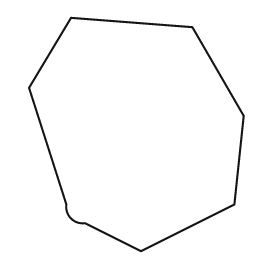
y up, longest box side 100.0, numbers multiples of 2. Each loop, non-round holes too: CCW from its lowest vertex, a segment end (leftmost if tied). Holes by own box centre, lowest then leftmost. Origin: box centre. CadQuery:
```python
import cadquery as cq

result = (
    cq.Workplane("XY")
    .moveTo(2.0, -50.0)
    .lineTo(42.0, -30.0)
    .lineTo(46.0, 8.0)
    .lineTo(24.0, 46.0)
    .lineTo(-28.0, 50.0)
    .lineTo(-46.0, 20.0)
    .lineTo(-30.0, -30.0)
    .threePointArc((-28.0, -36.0), (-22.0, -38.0))
    .close()
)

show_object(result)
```